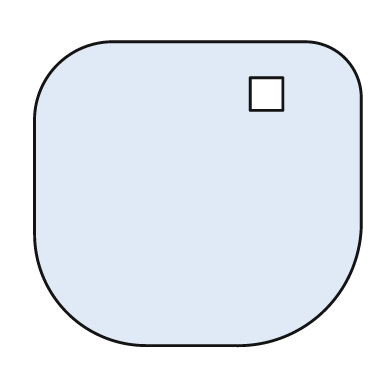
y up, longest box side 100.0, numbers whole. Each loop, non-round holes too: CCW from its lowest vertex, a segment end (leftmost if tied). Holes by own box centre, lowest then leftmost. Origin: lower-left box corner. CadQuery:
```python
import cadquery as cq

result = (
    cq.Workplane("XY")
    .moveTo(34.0, 0.0)
    .lineTo(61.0, 0.0)
    .threePointArc((89.0, 11.0), (100.0, 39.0))
    .lineTo(100.0, 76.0)
    .threePointArc((95.0, 88.0), (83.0, 93.0))
    .lineTo(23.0, 93.0)
    .threePointArc((7.0, 86.0), (0.0, 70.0))
    .lineTo(0.0, 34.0)
    .threePointArc((10.0, 10.0), (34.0, 0.0))
    .close()
    .moveTo(66.0, 72.0)
    .lineTo(76.0, 72.0)
    .lineTo(76.0, 82.0)
    .lineTo(66.0, 82.0)
    .close()
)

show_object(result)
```